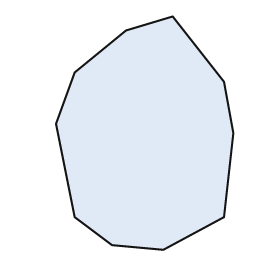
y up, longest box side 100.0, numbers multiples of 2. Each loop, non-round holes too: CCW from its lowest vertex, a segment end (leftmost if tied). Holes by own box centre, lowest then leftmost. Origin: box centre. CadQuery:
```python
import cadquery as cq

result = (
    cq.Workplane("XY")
    .moveTo(8.0, -50.0)
    .lineTo(34.0, -36.0)
    .lineTo(38.0, 0.0)
    .lineTo(34.0, 22.0)
    .lineTo(12.0, 50.0)
    .lineTo(-8.0, 44.0)
    .lineTo(-30.0, 26.0)
    .lineTo(-38.0, 4.0)
    .lineTo(-30.0, -36.0)
    .lineTo(-14.0, -48.0)
    .close()
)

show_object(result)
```